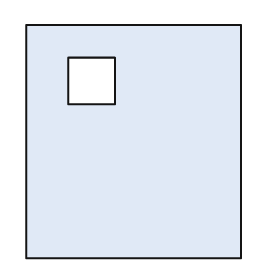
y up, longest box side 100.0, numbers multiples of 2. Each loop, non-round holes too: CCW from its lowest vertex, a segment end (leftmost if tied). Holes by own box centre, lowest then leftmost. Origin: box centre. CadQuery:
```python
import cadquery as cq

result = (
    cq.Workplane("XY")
    .moveTo(-46.0, -50.0)
    .lineTo(46.0, -50.0)
    .lineTo(46.0, 50.0)
    .lineTo(-46.0, 50.0)
    .close()
    .moveTo(-28.0, 16.0)
    .lineTo(-8.0, 16.0)
    .lineTo(-8.0, 36.0)
    .lineTo(-28.0, 36.0)
    .close()
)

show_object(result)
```